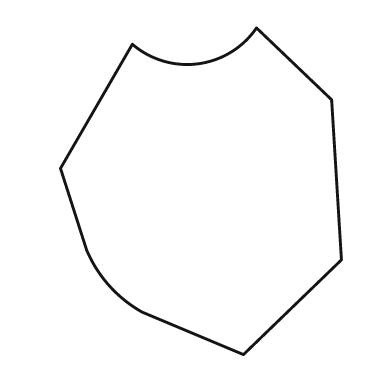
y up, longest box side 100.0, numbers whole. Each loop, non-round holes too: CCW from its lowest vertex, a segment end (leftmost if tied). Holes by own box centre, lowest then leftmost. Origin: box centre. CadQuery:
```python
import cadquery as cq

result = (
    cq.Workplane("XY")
    .moveTo(13.0, -50.0)
    .lineTo(43.0, -21.0)
    .lineTo(40.0, 28.0)
    .lineTo(17.0, 50.0)
    .threePointArc((-1.0, 39.0), (-21.0, 45.0))
    .lineTo(-43.0, 7.0)
    .lineTo(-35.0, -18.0)
    .threePointArc((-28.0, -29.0), (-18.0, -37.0))
    .close()
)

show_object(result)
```